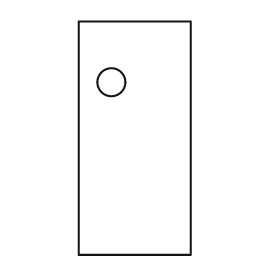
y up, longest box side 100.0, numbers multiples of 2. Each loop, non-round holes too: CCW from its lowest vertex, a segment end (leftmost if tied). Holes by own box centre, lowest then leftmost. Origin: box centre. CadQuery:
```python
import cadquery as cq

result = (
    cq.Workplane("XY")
    .moveTo(-24.0, -50.0)
    .lineTo(24.0, -50.0)
    .lineTo(24.0, 50.0)
    .lineTo(-24.0, 50.0)
    .close()
    .moveTo(-10.0, 24.0)
    .circle(6.0)
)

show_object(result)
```